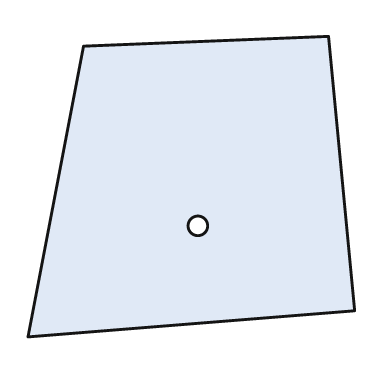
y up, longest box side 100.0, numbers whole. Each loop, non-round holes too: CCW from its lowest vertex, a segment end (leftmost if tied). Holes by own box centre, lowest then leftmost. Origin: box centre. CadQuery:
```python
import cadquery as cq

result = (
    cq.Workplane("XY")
    .moveTo(-50.0, -46.0)
    .lineTo(50.0, -38.0)
    .lineTo(42.0, 46.0)
    .lineTo(-33.0, 43.0)
    .close()
    .moveTo(2.0, -12.0)
    .circle(3.0)
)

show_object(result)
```